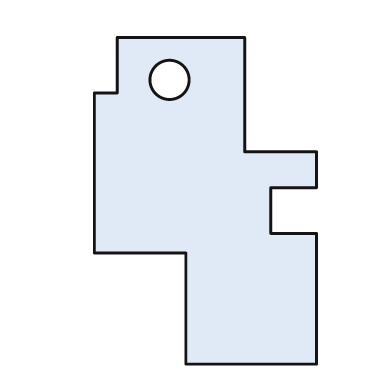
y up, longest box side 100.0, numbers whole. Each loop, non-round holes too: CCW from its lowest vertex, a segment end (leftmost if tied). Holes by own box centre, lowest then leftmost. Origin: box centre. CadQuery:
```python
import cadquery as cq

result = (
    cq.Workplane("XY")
    .moveTo(-6.0, -50.0)
    .lineTo(34.0, -50.0)
    .lineTo(34.0, -10.0)
    .lineTo(20.0, -10.0)
    .lineTo(20.0, 4.0)
    .lineTo(34.0, 4.0)
    .lineTo(34.0, 15.0)
    .lineTo(12.0, 15.0)
    .lineTo(12.0, 50.0)
    .lineTo(-27.0, 50.0)
    .lineTo(-27.0, 33.0)
    .lineTo(-34.0, 33.0)
    .lineTo(-34.0, -16.0)
    .lineTo(-6.0, -16.0)
    .close()
    .moveTo(-11.0, 37.0)
    .circle(6.0)
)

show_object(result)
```